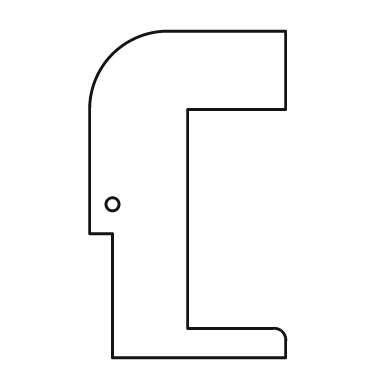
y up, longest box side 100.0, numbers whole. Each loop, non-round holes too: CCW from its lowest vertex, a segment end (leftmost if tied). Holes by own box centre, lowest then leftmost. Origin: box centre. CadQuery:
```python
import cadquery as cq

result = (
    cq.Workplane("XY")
    .moveTo(-23.0, -50.0)
    .lineTo(30.0, -50.0)
    .lineTo(30.0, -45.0)
    .threePointArc((29.0, -42.0), (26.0, -41.0))
    .lineTo(0.0, -41.0)
    .lineTo(0.0, 26.0)
    .lineTo(30.0, 26.0)
    .lineTo(30.0, 50.0)
    .lineTo(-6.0, 50.0)
    .threePointArc((-23.0, 43.0), (-30.0, 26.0))
    .lineTo(-30.0, -12.0)
    .lineTo(-23.0, -12.0)
    .close()
    .moveTo(-23.0, -3.0)
    .circle(2.0)
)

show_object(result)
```